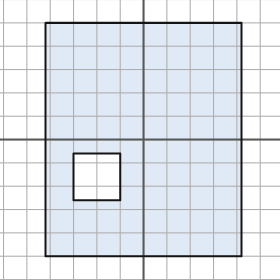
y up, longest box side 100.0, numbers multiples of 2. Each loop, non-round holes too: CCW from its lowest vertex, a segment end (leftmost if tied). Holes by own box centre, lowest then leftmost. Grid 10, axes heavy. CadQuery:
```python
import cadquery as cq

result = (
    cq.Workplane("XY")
    .moveTo(-42.0, -50.0)
    .lineTo(42.0, -50.0)
    .lineTo(42.0, 50.0)
    .lineTo(-42.0, 50.0)
    .close()
    .moveTo(-30.0, -26.0)
    .lineTo(-10.0, -26.0)
    .lineTo(-10.0, -6.0)
    .lineTo(-30.0, -6.0)
    .close()
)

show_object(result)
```